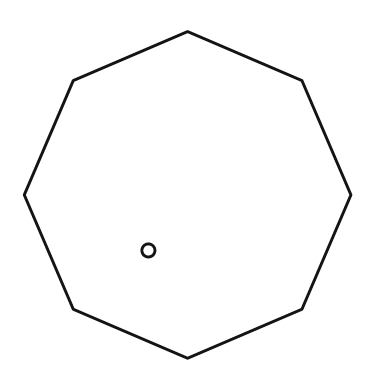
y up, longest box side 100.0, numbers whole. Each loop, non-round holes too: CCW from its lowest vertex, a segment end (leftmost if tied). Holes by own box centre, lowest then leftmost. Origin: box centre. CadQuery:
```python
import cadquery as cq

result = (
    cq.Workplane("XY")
    .moveTo(0.0, -50.0)
    .lineTo(35.0, -35.0)
    .lineTo(50.0, 0.0)
    .lineTo(35.0, 35.0)
    .lineTo(0.0, 50.0)
    .lineTo(-35.0, 35.0)
    .lineTo(-50.0, 0.0)
    .lineTo(-35.0, -35.0)
    .close()
    .moveTo(-12.0, -17.0)
    .circle(2.0)
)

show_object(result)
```